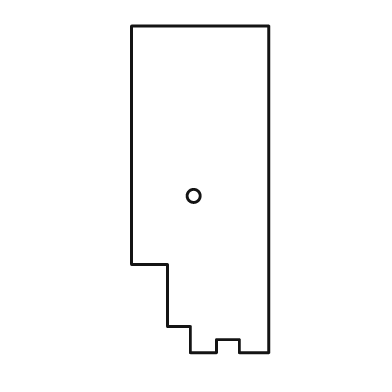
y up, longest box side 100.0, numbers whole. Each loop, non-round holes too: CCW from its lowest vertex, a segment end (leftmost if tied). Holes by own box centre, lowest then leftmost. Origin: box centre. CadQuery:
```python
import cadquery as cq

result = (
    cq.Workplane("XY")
    .moveTo(-3.0, -50.0)
    .lineTo(5.0, -50.0)
    .lineTo(5.0, -46.0)
    .lineTo(12.0, -46.0)
    .lineTo(12.0, -50.0)
    .lineTo(21.0, -50.0)
    .lineTo(21.0, 50.0)
    .lineTo(-21.0, 50.0)
    .lineTo(-21.0, -23.0)
    .lineTo(-10.0, -23.0)
    .lineTo(-10.0, -42.0)
    .lineTo(-3.0, -42.0)
    .close()
    .moveTo(-2.0, -2.0)
    .circle(2.0)
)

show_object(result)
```